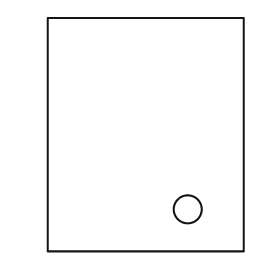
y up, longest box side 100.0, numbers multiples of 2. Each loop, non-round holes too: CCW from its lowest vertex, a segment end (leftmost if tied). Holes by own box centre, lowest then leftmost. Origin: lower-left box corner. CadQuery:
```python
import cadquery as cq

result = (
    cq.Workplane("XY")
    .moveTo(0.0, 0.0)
    .lineTo(84.0, 0.0)
    .lineTo(84.0, 100.0)
    .lineTo(0.0, 100.0)
    .close()
    .moveTo(60.0, 18.0)
    .circle(6.0)
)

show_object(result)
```